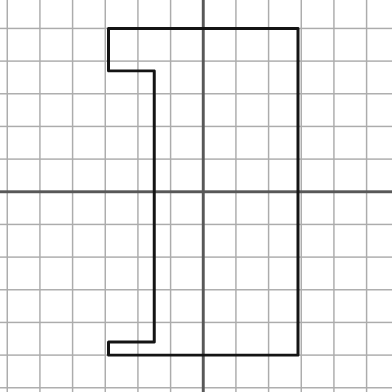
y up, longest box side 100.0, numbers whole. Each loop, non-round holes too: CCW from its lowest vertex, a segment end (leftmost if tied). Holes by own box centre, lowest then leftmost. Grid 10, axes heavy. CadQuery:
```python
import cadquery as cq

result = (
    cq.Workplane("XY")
    .moveTo(-29.0, -50.0)
    .lineTo(29.0, -50.0)
    .lineTo(29.0, 50.0)
    .lineTo(-29.0, 50.0)
    .lineTo(-29.0, 37.0)
    .lineTo(-15.0, 37.0)
    .lineTo(-15.0, -46.0)
    .lineTo(-29.0, -46.0)
    .close()
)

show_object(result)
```